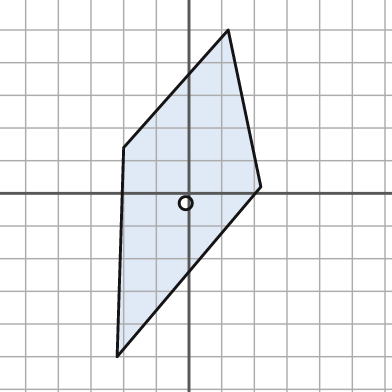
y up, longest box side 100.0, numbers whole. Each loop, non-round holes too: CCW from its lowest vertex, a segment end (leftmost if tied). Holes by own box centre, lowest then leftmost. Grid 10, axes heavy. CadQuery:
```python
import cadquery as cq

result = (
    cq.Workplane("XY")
    .moveTo(-22.0, -50.0)
    .lineTo(22.0, 2.0)
    .lineTo(12.0, 50.0)
    .lineTo(-20.0, 14.0)
    .close()
    .moveTo(-1.0, -3.0)
    .circle(2.0)
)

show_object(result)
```